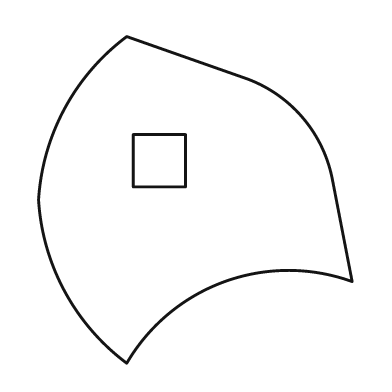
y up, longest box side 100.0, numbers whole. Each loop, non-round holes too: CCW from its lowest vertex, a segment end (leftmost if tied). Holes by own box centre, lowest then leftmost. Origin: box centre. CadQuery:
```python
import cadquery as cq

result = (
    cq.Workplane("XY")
    .moveTo(-21.0, -50.0)
    .threePointArc((9.0, -25.0), (48.0, -25.0))
    .lineTo(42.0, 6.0)
    .threePointArc((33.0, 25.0), (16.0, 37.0))
    .lineTo(-21.0, 50.0)
    .threePointArc((-40.0, 28.0), (-48.0, 0.0))
    .threePointArc((-40.0, -28.0), (-21.0, -50.0))
    .close()
    .moveTo(-19.0, 4.0)
    .lineTo(-3.0, 4.0)
    .lineTo(-3.0, 20.0)
    .lineTo(-19.0, 20.0)
    .close()
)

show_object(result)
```